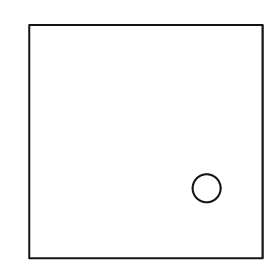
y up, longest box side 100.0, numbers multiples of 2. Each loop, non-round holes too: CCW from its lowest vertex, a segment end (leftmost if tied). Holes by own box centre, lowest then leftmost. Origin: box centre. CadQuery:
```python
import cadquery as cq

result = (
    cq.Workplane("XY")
    .moveTo(-50.0, -50.0)
    .lineTo(50.0, -50.0)
    .lineTo(50.0, 50.0)
    .lineTo(-50.0, 50.0)
    .close()
    .moveTo(26.0, -20.0)
    .circle(6.0)
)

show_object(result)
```